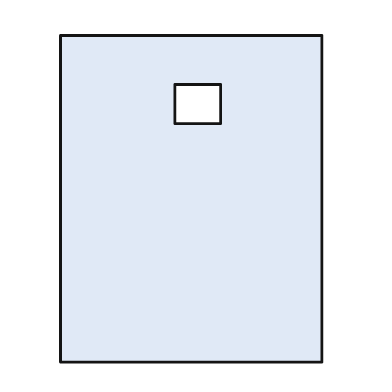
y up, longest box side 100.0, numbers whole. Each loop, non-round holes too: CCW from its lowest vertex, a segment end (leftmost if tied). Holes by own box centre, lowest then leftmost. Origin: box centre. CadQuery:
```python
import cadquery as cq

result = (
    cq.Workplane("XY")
    .moveTo(-40.0, -50.0)
    .lineTo(40.0, -50.0)
    .lineTo(40.0, 50.0)
    .lineTo(-40.0, 50.0)
    .close()
    .moveTo(-5.0, 23.0)
    .lineTo(9.0, 23.0)
    .lineTo(9.0, 35.0)
    .lineTo(-5.0, 35.0)
    .close()
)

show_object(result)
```